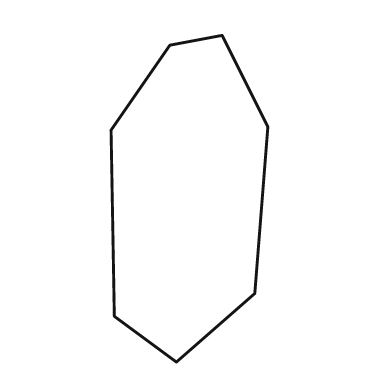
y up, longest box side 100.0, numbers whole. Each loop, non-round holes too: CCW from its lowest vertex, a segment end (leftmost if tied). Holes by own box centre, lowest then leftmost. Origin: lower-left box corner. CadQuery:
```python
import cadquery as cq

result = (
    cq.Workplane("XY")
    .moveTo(20.0, 0.0)
    .lineTo(44.0, 21.0)
    .lineTo(48.0, 72.0)
    .lineTo(34.0, 100.0)
    .lineTo(18.0, 97.0)
    .lineTo(0.0, 71.0)
    .lineTo(1.0, 14.0)
    .close()
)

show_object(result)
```